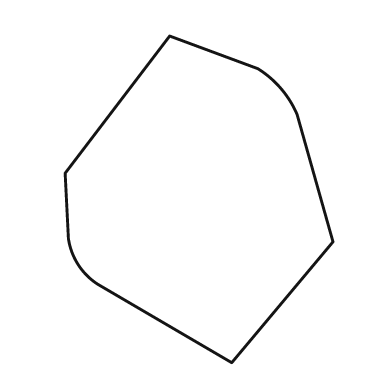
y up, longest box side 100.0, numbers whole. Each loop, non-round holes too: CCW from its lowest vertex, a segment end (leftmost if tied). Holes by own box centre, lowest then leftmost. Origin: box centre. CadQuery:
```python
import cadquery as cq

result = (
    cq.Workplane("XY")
    .moveTo(10.0, -50.0)
    .lineTo(41.0, -13.0)
    .lineTo(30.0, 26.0)
    .threePointArc((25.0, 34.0), (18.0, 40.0))
    .lineTo(-9.0, 50.0)
    .lineTo(-41.0, 8.0)
    .lineTo(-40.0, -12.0)
    .threePointArc((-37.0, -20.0), (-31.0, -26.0))
    .close()
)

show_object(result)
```